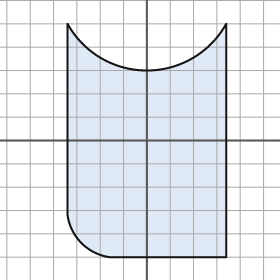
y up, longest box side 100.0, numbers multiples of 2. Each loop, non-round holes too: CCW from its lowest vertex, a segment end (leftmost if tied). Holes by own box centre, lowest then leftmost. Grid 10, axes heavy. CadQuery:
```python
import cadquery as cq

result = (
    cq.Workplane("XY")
    .moveTo(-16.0, -50.0)
    .lineTo(34.0, -50.0)
    .lineTo(34.0, 50.0)
    .threePointArc((0.0, 30.0), (-34.0, 50.0))
    .lineTo(-34.0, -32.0)
    .threePointArc((-28.0, -44.0), (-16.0, -50.0))
    .close()
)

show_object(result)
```